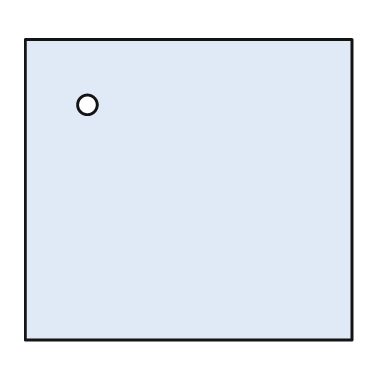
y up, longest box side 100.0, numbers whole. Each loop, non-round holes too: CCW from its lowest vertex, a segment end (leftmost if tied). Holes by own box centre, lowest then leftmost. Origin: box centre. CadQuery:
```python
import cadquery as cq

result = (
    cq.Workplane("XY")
    .moveTo(-50.0, -46.0)
    .lineTo(50.0, -46.0)
    .lineTo(50.0, 46.0)
    .lineTo(-50.0, 46.0)
    .close()
    .moveTo(-31.0, 26.0)
    .circle(3.0)
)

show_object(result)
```